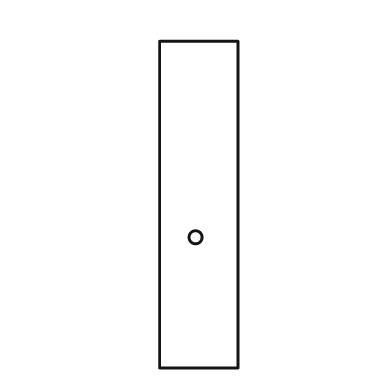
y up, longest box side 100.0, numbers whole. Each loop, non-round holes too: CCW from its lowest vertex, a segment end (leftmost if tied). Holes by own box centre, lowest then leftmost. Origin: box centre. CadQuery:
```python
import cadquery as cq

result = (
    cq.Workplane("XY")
    .moveTo(-12.0, -50.0)
    .lineTo(12.0, -50.0)
    .lineTo(12.0, 50.0)
    .lineTo(-12.0, 50.0)
    .close()
    .moveTo(-1.0, -10.0)
    .circle(2.0)
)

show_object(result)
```